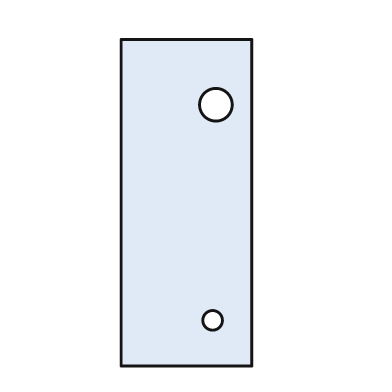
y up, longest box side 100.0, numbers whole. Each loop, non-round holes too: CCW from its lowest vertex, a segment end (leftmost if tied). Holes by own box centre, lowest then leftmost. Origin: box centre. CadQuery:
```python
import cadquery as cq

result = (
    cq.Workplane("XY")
    .moveTo(-20.0, -50.0)
    .lineTo(20.0, -50.0)
    .lineTo(20.0, 50.0)
    .lineTo(-20.0, 50.0)
    .close()
    .moveTo(8.0, -36.0)
    .circle(3.0)
    .moveTo(9.0, 30.0)
    .circle(5.0)
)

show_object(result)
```